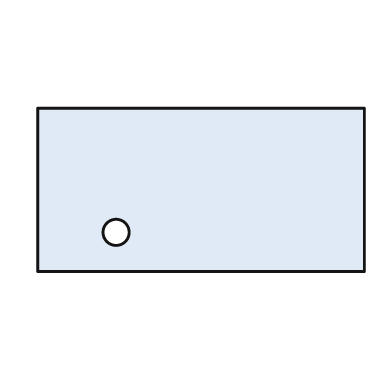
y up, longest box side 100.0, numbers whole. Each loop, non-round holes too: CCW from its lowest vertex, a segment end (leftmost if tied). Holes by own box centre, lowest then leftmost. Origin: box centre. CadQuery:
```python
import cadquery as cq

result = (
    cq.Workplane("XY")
    .moveTo(-50.0, -25.0)
    .lineTo(50.0, -25.0)
    .lineTo(50.0, 25.0)
    .lineTo(-50.0, 25.0)
    .close()
    .moveTo(-26.0, -13.0)
    .circle(4.0)
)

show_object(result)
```